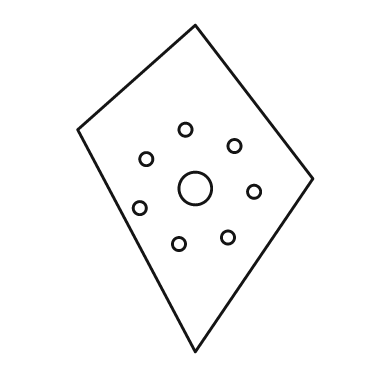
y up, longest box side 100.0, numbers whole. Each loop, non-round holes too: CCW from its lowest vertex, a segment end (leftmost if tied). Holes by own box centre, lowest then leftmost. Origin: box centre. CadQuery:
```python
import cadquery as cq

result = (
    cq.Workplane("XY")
    .moveTo(0.0, -50.0)
    .lineTo(36.0, 3.0)
    .lineTo(0.0, 50.0)
    .lineTo(-36.0, 18.0)
    .close()
    .moveTo(-5.0, -17.0)
    .circle(2.0)
    .moveTo(10.0, -15.0)
    .circle(2.0)
    .moveTo(-17.0, -6.0)
    .circle(2.0)
    .moveTo(18.0, -1.0)
    .circle(2.0)
    .moveTo(0.0, 0.0)
    .circle(5.0)
    .moveTo(-15.0, 9.0)
    .circle(2.0)
    .moveTo(12.0, 13.0)
    .circle(2.0)
    .moveTo(-3.0, 18.0)
    .circle(2.0)
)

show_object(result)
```